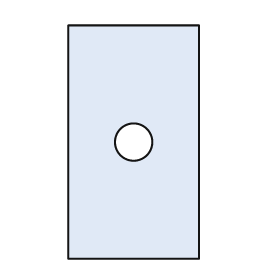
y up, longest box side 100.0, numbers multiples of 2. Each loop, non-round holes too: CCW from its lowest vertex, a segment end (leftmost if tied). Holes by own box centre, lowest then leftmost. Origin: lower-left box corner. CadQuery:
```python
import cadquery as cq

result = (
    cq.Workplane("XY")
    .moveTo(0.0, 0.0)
    .lineTo(56.0, 0.0)
    .lineTo(56.0, 100.0)
    .lineTo(0.0, 100.0)
    .close()
    .moveTo(28.0, 50.0)
    .circle(8.0)
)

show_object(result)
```